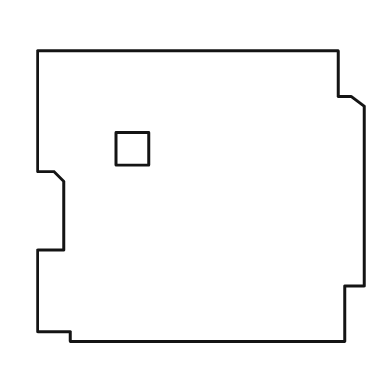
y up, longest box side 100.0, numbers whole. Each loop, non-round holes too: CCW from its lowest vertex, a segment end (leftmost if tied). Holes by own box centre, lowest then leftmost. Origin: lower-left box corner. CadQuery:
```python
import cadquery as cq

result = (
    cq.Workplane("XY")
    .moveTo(10.0, 0.0)
    .lineTo(94.0, 0.0)
    .lineTo(94.0, 17.0)
    .lineTo(100.0, 17.0)
    .lineTo(100.0, 72.0)
    .lineTo(96.0, 75.0)
    .lineTo(92.0, 75.0)
    .lineTo(92.0, 89.0)
    .lineTo(0.0, 89.0)
    .lineTo(0.0, 52.0)
    .lineTo(5.0, 52.0)
    .lineTo(8.0, 49.0)
    .lineTo(8.0, 28.0)
    .lineTo(0.0, 28.0)
    .lineTo(0.0, 3.0)
    .lineTo(10.0, 3.0)
    .close()
    .moveTo(24.0, 54.0)
    .lineTo(34.0, 54.0)
    .lineTo(34.0, 64.0)
    .lineTo(24.0, 64.0)
    .close()
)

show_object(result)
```